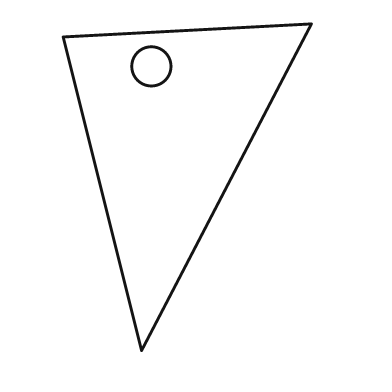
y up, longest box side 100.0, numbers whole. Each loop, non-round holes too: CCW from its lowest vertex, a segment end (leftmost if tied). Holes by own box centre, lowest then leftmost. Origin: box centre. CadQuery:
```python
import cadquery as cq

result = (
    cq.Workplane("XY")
    .moveTo(-14.0, -50.0)
    .lineTo(38.0, 50.0)
    .lineTo(-38.0, 46.0)
    .close()
    .moveTo(-11.0, 37.0)
    .circle(6.0)
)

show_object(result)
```